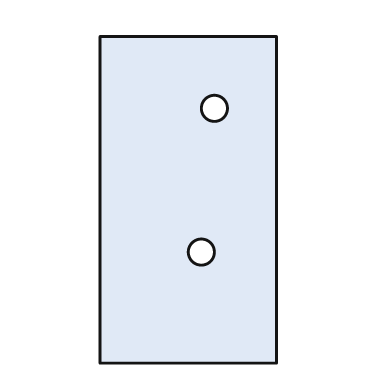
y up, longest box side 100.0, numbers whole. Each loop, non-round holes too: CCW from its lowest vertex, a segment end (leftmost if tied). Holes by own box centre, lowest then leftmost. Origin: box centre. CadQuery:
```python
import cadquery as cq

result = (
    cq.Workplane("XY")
    .moveTo(-27.0, -50.0)
    .lineTo(27.0, -50.0)
    .lineTo(27.0, 50.0)
    .lineTo(-27.0, 50.0)
    .close()
    .moveTo(4.0, -16.0)
    .circle(4.0)
    .moveTo(8.0, 28.0)
    .circle(4.0)
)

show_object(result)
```